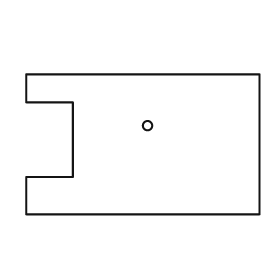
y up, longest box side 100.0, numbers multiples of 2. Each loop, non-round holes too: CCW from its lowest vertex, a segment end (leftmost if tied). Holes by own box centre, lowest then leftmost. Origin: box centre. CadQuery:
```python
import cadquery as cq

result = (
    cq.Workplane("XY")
    .moveTo(-50.0, -30.0)
    .lineTo(50.0, -30.0)
    .lineTo(50.0, 30.0)
    .lineTo(-50.0, 30.0)
    .lineTo(-50.0, 18.0)
    .lineTo(-30.0, 18.0)
    .lineTo(-30.0, -14.0)
    .lineTo(-50.0, -14.0)
    .close()
    .moveTo(2.0, 8.0)
    .circle(2.0)
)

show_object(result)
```